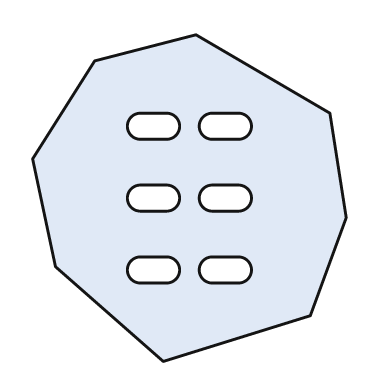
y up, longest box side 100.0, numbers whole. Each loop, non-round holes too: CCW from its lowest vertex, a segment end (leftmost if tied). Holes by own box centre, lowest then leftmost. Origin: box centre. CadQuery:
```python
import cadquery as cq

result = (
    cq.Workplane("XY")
    .moveTo(-8.0, -50.0)
    .lineTo(37.0, -36.0)
    .lineTo(48.0, -6.0)
    .lineTo(43.0, 26.0)
    .lineTo(2.0, 50.0)
    .lineTo(-29.0, 42.0)
    .lineTo(-48.0, 12.0)
    .lineTo(-41.0, -21.0)
    .close()
    .moveTo(-15.0, -26.0)
    .lineTo(-7.0, -26.0)
    .threePointArc((-3.0, -22.0), (-7.0, -18.0))
    .lineTo(-15.0, -18.0)
    .threePointArc((-19.0, -22.0), (-15.0, -26.0))
    .close()
    .moveTo(7.0, -26.0)
    .lineTo(15.0, -26.0)
    .threePointArc((19.0, -22.0), (15.0, -18.0))
    .lineTo(7.0, -18.0)
    .threePointArc((3.0, -22.0), (7.0, -26.0))
    .close()
    .moveTo(-15.0, -4.0)
    .lineTo(-7.0, -4.0)
    .threePointArc((-3.0, 0.0), (-7.0, 4.0))
    .lineTo(-15.0, 4.0)
    .threePointArc((-19.0, 0.0), (-15.0, -4.0))
    .close()
    .moveTo(7.0, -4.0)
    .lineTo(15.0, -4.0)
    .threePointArc((19.0, 0.0), (15.0, 4.0))
    .lineTo(7.0, 4.0)
    .threePointArc((3.0, 0.0), (7.0, -4.0))
    .close()
    .moveTo(-15.0, 18.0)
    .lineTo(-7.0, 18.0)
    .threePointArc((-3.0, 22.0), (-7.0, 26.0))
    .lineTo(-15.0, 26.0)
    .threePointArc((-19.0, 22.0), (-15.0, 18.0))
    .close()
    .moveTo(7.0, 18.0)
    .lineTo(15.0, 18.0)
    .threePointArc((19.0, 22.0), (15.0, 26.0))
    .lineTo(7.0, 26.0)
    .threePointArc((3.0, 22.0), (7.0, 18.0))
    .close()
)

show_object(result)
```